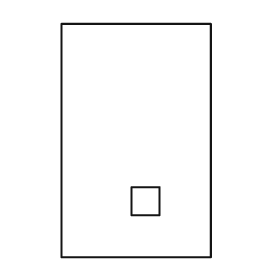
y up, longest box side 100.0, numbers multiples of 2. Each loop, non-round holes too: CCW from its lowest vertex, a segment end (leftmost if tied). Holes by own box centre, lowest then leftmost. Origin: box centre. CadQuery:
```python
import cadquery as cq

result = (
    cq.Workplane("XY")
    .moveTo(-32.0, -50.0)
    .lineTo(32.0, -50.0)
    .lineTo(32.0, 50.0)
    .lineTo(-32.0, 50.0)
    .close()
    .moveTo(-2.0, -32.0)
    .lineTo(10.0, -32.0)
    .lineTo(10.0, -20.0)
    .lineTo(-2.0, -20.0)
    .close()
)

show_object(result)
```